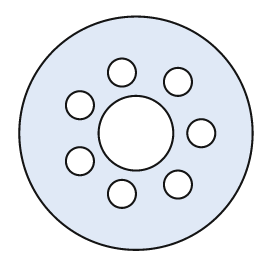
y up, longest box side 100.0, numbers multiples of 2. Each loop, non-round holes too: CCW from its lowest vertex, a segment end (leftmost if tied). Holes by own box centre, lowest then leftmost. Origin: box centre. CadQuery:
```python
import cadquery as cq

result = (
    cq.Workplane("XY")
    .moveTo(0.0, 0.0)
    .circle(50.0)
    .moveTo(-6.0, -26.0)
    .circle(6.0)
    .moveTo(18.0, -22.0)
    .circle(6.0)
    .moveTo(-24.0, -12.0)
    .circle(6.0)
    .moveTo(0.0, 0.0)
    .circle(16.0)
    .moveTo(28.0, 0.0)
    .circle(6.0)
    .moveTo(-24.0, 12.0)
    .circle(6.0)
    .moveTo(18.0, 22.0)
    .circle(6.0)
    .moveTo(-6.0, 26.0)
    .circle(6.0)
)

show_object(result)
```